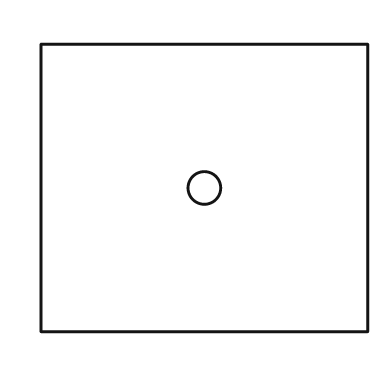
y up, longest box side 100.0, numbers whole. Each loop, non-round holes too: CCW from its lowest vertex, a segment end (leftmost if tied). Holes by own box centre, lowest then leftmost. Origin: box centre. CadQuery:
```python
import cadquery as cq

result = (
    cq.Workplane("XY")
    .moveTo(-50.0, -44.0)
    .lineTo(50.0, -44.0)
    .lineTo(50.0, 44.0)
    .lineTo(-50.0, 44.0)
    .close()
    .moveTo(0.0, 0.0)
    .circle(5.0)
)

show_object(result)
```